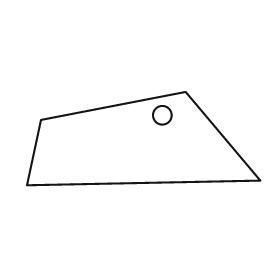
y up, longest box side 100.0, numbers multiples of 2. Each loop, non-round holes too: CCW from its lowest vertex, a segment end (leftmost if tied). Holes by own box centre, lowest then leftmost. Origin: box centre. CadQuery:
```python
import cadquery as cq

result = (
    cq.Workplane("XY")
    .moveTo(-50.0, -20.0)
    .lineTo(50.0, -18.0)
    .lineTo(18.0, 20.0)
    .lineTo(-44.0, 8.0)
    .close()
    .moveTo(8.0, 10.0)
    .circle(4.0)
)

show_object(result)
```